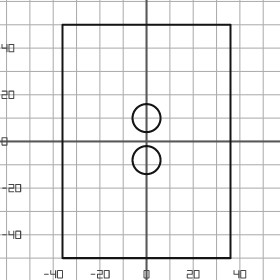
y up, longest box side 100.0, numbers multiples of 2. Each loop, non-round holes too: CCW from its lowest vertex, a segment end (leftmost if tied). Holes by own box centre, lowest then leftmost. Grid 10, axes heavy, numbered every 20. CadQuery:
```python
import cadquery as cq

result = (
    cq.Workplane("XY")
    .moveTo(-36.0, -50.0)
    .lineTo(36.0, -50.0)
    .lineTo(36.0, 50.0)
    .lineTo(-36.0, 50.0)
    .close()
    .moveTo(0.0, -8.0)
    .circle(6.0)
    .moveTo(0.0, 10.0)
    .circle(6.0)
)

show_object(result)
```